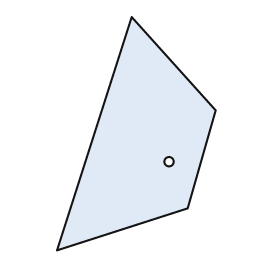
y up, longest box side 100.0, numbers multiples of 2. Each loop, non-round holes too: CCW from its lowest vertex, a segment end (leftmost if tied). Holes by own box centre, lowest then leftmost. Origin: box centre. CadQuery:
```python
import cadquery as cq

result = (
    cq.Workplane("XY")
    .moveTo(-34.0, -50.0)
    .lineTo(22.0, -32.0)
    .lineTo(34.0, 10.0)
    .lineTo(-2.0, 50.0)
    .close()
    .moveTo(14.0, -12.0)
    .circle(2.0)
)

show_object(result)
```